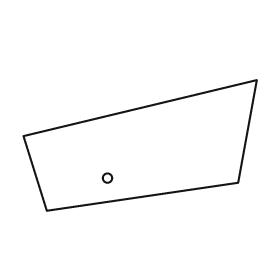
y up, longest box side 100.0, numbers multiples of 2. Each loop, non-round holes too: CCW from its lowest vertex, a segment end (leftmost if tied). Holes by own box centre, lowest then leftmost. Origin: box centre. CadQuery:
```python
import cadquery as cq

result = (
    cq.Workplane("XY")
    .moveTo(-40.0, -28.0)
    .lineTo(42.0, -16.0)
    .lineTo(50.0, 28.0)
    .lineTo(-50.0, 4.0)
    .close()
    .moveTo(-14.0, -14.0)
    .circle(2.0)
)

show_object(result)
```